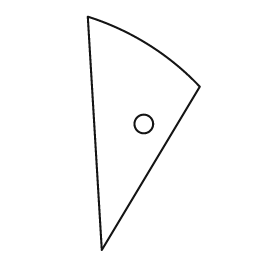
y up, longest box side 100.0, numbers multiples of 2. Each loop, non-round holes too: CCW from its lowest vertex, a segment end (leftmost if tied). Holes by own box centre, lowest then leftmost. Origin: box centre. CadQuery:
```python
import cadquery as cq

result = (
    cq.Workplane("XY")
    .moveTo(-18.0, -50.0)
    .lineTo(24.0, 20.0)
    .threePointArc((2.0, 38.0), (-24.0, 50.0))
    .close()
    .moveTo(0.0, 4.0)
    .circle(4.0)
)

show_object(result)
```